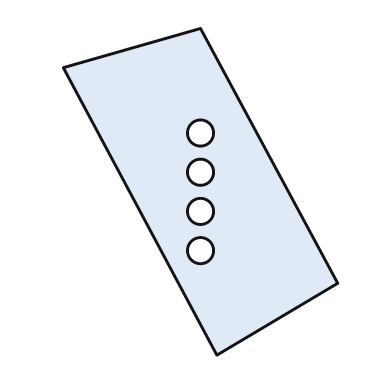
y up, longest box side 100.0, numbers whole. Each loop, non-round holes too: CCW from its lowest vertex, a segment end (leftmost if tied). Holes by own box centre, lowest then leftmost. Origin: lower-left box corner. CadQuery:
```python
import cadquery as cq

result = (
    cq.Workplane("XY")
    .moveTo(47.0, 0.0)
    .lineTo(84.0, 22.0)
    .lineTo(42.0, 100.0)
    .lineTo(0.0, 88.0)
    .close()
    .moveTo(42.0, 32.0)
    .circle(4.0)
    .moveTo(42.0, 44.0)
    .circle(4.0)
    .moveTo(42.0, 56.0)
    .circle(4.0)
    .moveTo(42.0, 68.0)
    .circle(4.0)
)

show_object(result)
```